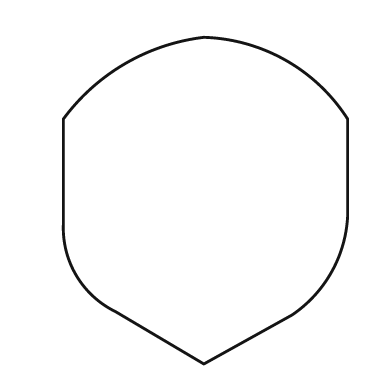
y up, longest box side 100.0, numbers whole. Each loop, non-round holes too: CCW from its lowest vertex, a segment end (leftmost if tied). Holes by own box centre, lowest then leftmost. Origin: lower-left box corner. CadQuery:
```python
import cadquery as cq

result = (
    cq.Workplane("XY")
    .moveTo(43.0, 0.0)
    .lineTo(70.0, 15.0)
    .threePointArc((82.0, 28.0), (87.0, 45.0))
    .lineTo(87.0, 75.0)
    .threePointArc((68.0, 93.0), (43.0, 100.0))
    .threePointArc((19.0, 92.0), (0.0, 75.0))
    .lineTo(0.0, 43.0)
    .threePointArc((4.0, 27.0), (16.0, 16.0))
    .close()
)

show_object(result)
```